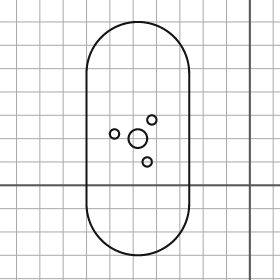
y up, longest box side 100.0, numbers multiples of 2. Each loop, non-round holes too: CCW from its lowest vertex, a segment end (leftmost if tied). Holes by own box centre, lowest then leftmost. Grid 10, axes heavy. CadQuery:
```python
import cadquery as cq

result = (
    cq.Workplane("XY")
    .moveTo(-70.0, -8.0)
    .threePointArc((-48.0, -30.0), (-26.0, -8.0))
    .lineTo(-26.0, 48.0)
    .threePointArc((-48.0, 70.0), (-70.0, 48.0))
    .close()
    .moveTo(-44.0, 10.0)
    .circle(2.0)
    .moveTo(-48.0, 20.0)
    .circle(4.0)
    .moveTo(-58.0, 22.0)
    .circle(2.0)
    .moveTo(-42.0, 28.0)
    .circle(2.0)
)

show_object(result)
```